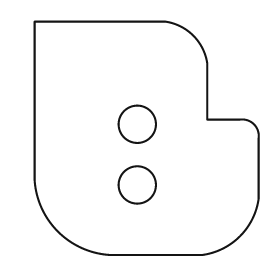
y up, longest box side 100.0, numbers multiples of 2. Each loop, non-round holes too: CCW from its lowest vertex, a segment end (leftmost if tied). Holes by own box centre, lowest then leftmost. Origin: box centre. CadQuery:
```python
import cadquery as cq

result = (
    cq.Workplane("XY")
    .moveTo(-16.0, -50.0)
    .lineTo(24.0, -50.0)
    .threePointArc((40.0, -42.0), (48.0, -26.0))
    .lineTo(48.0, 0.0)
    .threePointArc((46.0, 6.0), (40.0, 8.0))
    .lineTo(26.0, 8.0)
    .lineTo(26.0, 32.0)
    .threePointArc((20.0, 44.0), (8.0, 50.0))
    .lineTo(-48.0, 50.0)
    .lineTo(-48.0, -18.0)
    .threePointArc((-38.0, -40.0), (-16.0, -50.0))
    .close()
    .moveTo(-4.0, -20.0)
    .circle(8.0)
    .moveTo(-4.0, 6.0)
    .circle(8.0)
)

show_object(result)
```